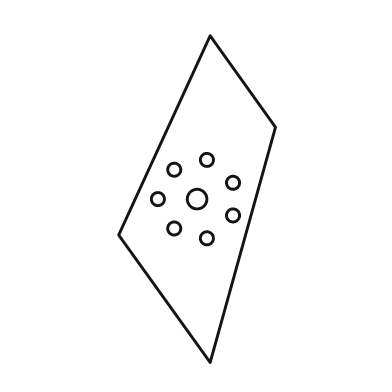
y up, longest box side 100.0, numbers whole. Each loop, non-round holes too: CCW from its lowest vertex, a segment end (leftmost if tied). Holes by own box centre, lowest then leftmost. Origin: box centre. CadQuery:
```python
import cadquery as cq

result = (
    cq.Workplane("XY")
    .moveTo(4.0, -50.0)
    .lineTo(24.0, 22.0)
    .lineTo(4.0, 50.0)
    .lineTo(-24.0, -11.0)
    .close()
    .moveTo(3.0, -12.0)
    .circle(2.0)
    .moveTo(-7.0, -9.0)
    .circle(2.0)
    .moveTo(11.0, -5.0)
    .circle(2.0)
    .moveTo(-12.0, 0.0)
    .circle(2.0)
    .moveTo(0.0, 0.0)
    .circle(3.0)
    .moveTo(11.0, 5.0)
    .circle(2.0)
    .moveTo(-7.0, 9.0)
    .circle(2.0)
    .moveTo(3.0, 12.0)
    .circle(2.0)
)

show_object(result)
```